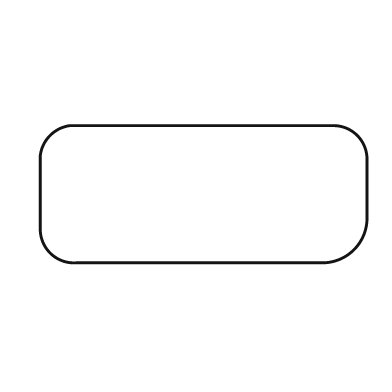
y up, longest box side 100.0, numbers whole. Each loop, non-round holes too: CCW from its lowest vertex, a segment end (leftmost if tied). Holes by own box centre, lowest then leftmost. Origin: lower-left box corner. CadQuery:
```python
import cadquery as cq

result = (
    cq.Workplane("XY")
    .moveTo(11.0, 0.0)
    .lineTo(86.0, 0.0)
    .threePointArc((96.0, 4.0), (100.0, 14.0))
    .lineTo(100.0, 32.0)
    .threePointArc((97.0, 39.0), (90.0, 42.0))
    .lineTo(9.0, 42.0)
    .threePointArc((3.0, 39.0), (0.0, 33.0))
    .lineTo(0.0, 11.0)
    .threePointArc((3.0, 3.0), (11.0, 0.0))
    .close()
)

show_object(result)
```